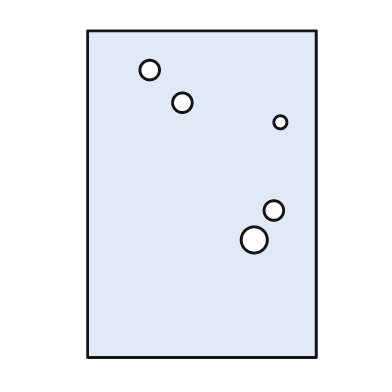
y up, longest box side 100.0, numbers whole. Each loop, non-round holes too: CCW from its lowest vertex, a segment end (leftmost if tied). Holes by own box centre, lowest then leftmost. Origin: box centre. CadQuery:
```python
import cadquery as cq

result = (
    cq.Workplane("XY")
    .moveTo(-35.0, -50.0)
    .lineTo(35.0, -50.0)
    .lineTo(35.0, 50.0)
    .lineTo(-35.0, 50.0)
    .close()
    .moveTo(16.0, -14.0)
    .circle(4.0)
    .moveTo(22.0, -5.0)
    .circle(3.0)
    .moveTo(24.0, 22.0)
    .circle(2.0)
    .moveTo(-6.0, 28.0)
    .circle(3.0)
    .moveTo(-16.0, 38.0)
    .circle(3.0)
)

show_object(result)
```